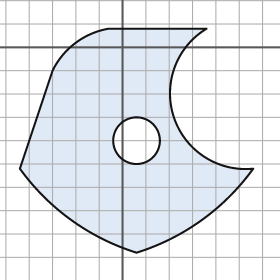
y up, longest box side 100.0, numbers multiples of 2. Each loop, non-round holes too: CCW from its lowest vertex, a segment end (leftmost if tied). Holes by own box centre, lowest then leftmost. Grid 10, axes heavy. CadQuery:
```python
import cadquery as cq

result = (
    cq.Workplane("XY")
    .moveTo(6.0, -88.0)
    .threePointArc((34.0, -74.0), (56.0, -52.0))
    .threePointArc((22.0, -30.0), (36.0, 8.0))
    .lineTo(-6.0, 8.0)
    .threePointArc((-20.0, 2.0), (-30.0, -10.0))
    .lineTo(-44.0, -52.0)
    .threePointArc((-22.0, -74.0), (6.0, -88.0))
    .close()
    .moveTo(6.0, -40.0)
    .circle(10.0)
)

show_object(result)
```